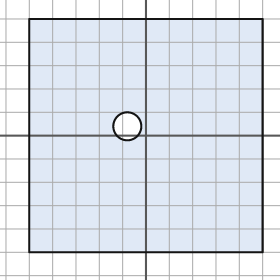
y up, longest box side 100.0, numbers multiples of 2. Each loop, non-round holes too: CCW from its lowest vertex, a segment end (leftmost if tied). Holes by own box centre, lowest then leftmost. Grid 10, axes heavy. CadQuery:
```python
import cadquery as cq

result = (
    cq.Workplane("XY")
    .moveTo(-50.0, -50.0)
    .lineTo(50.0, -50.0)
    .lineTo(50.0, 50.0)
    .lineTo(-50.0, 50.0)
    .close()
    .moveTo(-8.0, 4.0)
    .circle(6.0)
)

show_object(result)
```